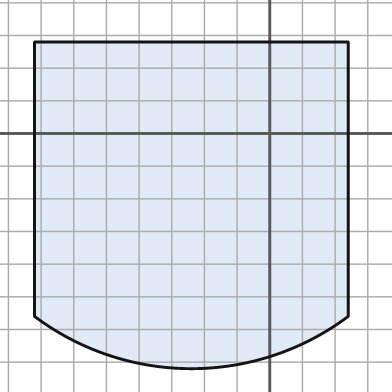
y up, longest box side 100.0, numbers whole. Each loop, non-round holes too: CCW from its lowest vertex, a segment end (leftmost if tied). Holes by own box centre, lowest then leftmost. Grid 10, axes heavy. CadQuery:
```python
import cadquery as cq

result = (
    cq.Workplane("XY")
    .moveTo(-72.0, -56.0)
    .threePointArc((-24.0, -72.0), (24.0, -56.0))
    .lineTo(24.0, 28.0)
    .lineTo(-72.0, 28.0)
    .close()
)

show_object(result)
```